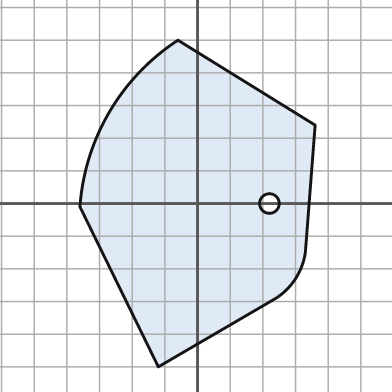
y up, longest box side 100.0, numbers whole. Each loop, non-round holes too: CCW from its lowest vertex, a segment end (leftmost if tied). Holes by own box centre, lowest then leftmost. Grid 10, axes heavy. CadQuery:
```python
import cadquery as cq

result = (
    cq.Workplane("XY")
    .moveTo(-12.0, -50.0)
    .lineTo(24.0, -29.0)
    .threePointArc((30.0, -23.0), (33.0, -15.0))
    .lineTo(36.0, 24.0)
    .lineTo(-6.0, 50.0)
    .threePointArc((-27.0, 28.0), (-36.0, -1.0))
    .close()
    .moveTo(22.0, 0.0)
    .circle(3.0)
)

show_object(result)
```